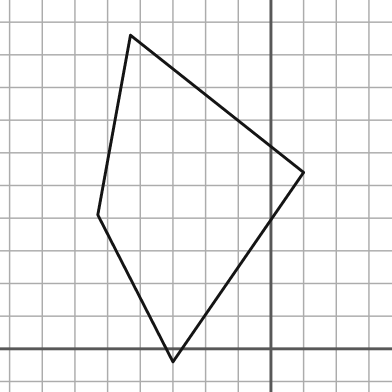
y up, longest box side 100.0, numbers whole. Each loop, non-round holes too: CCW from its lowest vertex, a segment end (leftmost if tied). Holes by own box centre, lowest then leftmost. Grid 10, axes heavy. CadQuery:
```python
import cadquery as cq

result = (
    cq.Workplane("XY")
    .moveTo(-30.0, -4.0)
    .lineTo(10.0, 54.0)
    .lineTo(-43.0, 96.0)
    .lineTo(-53.0, 41.0)
    .close()
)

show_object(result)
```